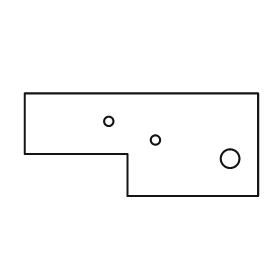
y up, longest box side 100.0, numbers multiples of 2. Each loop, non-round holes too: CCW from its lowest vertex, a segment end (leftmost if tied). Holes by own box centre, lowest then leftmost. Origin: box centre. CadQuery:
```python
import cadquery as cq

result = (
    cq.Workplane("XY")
    .moveTo(-6.0, -22.0)
    .lineTo(50.0, -22.0)
    .lineTo(50.0, 22.0)
    .lineTo(-50.0, 22.0)
    .lineTo(-50.0, -4.0)
    .lineTo(-6.0, -4.0)
    .close()
    .moveTo(38.0, -6.0)
    .circle(4.0)
    .moveTo(6.0, 2.0)
    .circle(2.0)
    .moveTo(-14.0, 10.0)
    .circle(2.0)
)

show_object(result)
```